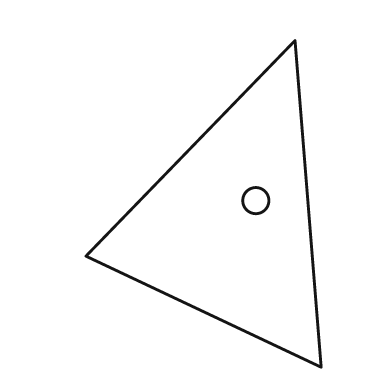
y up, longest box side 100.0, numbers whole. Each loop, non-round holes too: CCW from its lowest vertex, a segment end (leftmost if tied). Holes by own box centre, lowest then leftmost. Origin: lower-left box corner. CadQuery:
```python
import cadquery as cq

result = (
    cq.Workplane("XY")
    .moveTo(72.0, 0.0)
    .lineTo(64.0, 100.0)
    .lineTo(0.0, 34.0)
    .close()
    .moveTo(52.0, 51.0)
    .circle(4.0)
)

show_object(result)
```